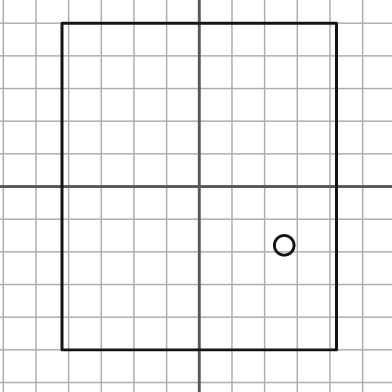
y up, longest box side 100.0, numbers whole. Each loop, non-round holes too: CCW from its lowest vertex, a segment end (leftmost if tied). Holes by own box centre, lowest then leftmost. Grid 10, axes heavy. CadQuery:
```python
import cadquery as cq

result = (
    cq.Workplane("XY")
    .moveTo(-42.0, -50.0)
    .lineTo(42.0, -50.0)
    .lineTo(42.0, 50.0)
    .lineTo(-42.0, 50.0)
    .close()
    .moveTo(26.0, -18.0)
    .circle(3.0)
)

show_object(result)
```